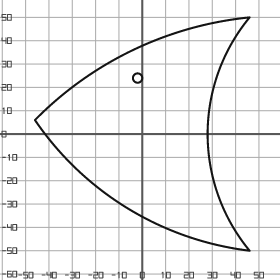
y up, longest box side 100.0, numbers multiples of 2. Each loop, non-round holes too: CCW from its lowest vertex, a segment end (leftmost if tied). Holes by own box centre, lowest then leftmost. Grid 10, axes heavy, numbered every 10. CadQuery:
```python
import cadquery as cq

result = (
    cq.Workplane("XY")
    .moveTo(46.0, -50.0)
    .threePointArc((28.0, 0.0), (46.0, 50.0))
    .threePointArc((-4.0, 36.0), (-46.0, 6.0))
    .threePointArc((-6.0, -32.0), (46.0, -50.0))
    .close()
    .moveTo(-2.0, 24.0)
    .circle(2.0)
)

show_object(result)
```